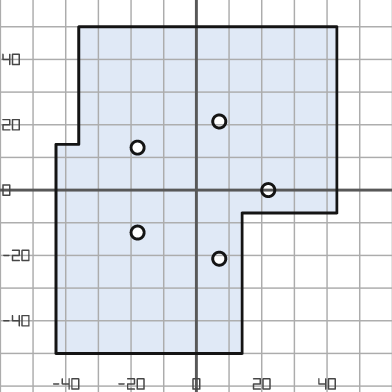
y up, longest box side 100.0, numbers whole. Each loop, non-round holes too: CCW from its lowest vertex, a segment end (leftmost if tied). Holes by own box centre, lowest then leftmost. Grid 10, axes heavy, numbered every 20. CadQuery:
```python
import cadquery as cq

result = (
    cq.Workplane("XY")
    .moveTo(-43.0, -50.0)
    .lineTo(14.0, -50.0)
    .lineTo(14.0, -7.0)
    .lineTo(43.0, -7.0)
    .lineTo(43.0, 50.0)
    .lineTo(-36.0, 50.0)
    .lineTo(-36.0, 14.0)
    .lineTo(-43.0, 14.0)
    .close()
    .moveTo(7.0, -21.0)
    .circle(2.0)
    .moveTo(-18.0, -13.0)
    .circle(2.0)
    .moveTo(22.0, 0.0)
    .circle(2.0)
    .moveTo(-18.0, 13.0)
    .circle(2.0)
    .moveTo(7.0, 21.0)
    .circle(2.0)
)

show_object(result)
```